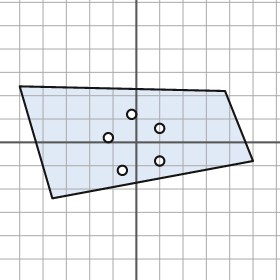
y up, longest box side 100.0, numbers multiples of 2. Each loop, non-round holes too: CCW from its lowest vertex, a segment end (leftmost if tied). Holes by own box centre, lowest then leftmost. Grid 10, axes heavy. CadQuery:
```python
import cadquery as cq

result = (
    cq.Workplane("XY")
    .moveTo(-36.0, -24.0)
    .lineTo(50.0, -8.0)
    .lineTo(38.0, 22.0)
    .lineTo(-50.0, 24.0)
    .close()
    .moveTo(-6.0, -12.0)
    .circle(2.0)
    .moveTo(10.0, -8.0)
    .circle(2.0)
    .moveTo(-12.0, 2.0)
    .circle(2.0)
    .moveTo(10.0, 6.0)
    .circle(2.0)
    .moveTo(-2.0, 12.0)
    .circle(2.0)
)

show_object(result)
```